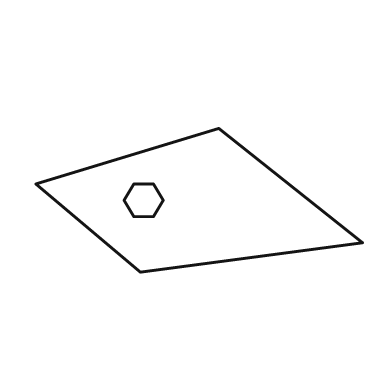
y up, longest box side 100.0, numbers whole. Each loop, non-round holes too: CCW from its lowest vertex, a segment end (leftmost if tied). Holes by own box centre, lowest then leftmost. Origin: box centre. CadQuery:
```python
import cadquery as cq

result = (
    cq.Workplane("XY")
    .moveTo(-18.0, -22.0)
    .lineTo(50.0, -13.0)
    .lineTo(6.0, 22.0)
    .lineTo(-50.0, 5.0)
    .close()
    .moveTo(-20.0, -5.0)
    .lineTo(-14.0, -5.0)
    .lineTo(-11.0, 0.0)
    .lineTo(-14.0, 5.0)
    .lineTo(-20.0, 5.0)
    .lineTo(-23.0, 0.0)
    .close()
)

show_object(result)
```